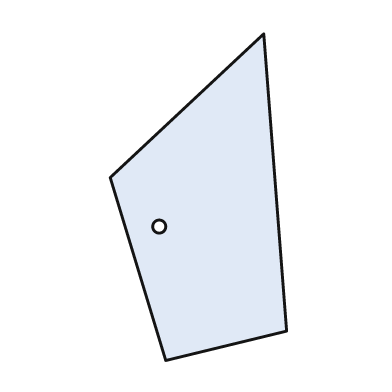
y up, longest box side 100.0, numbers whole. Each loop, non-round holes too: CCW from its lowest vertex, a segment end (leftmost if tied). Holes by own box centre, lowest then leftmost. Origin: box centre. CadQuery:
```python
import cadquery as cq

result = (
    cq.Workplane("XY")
    .moveTo(-10.0, -50.0)
    .lineTo(27.0, -41.0)
    .lineTo(20.0, 50.0)
    .lineTo(-27.0, 6.0)
    .close()
    .moveTo(-12.0, -9.0)
    .circle(2.0)
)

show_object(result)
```